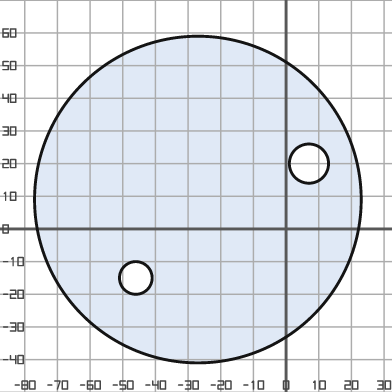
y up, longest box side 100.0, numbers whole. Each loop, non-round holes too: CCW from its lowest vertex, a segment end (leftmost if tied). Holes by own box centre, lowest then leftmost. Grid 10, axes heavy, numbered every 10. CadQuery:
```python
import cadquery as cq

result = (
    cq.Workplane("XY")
    .moveTo(-27.0, 9.0)
    .circle(50.0)
    .moveTo(-46.0, -15.0)
    .circle(5.0)
    .moveTo(7.0, 20.0)
    .circle(6.0)
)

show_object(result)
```